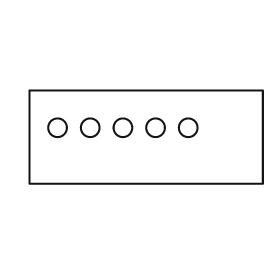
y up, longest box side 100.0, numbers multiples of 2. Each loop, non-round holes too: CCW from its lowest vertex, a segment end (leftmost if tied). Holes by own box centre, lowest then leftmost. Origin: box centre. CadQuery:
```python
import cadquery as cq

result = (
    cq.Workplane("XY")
    .moveTo(-50.0, -20.0)
    .lineTo(50.0, -20.0)
    .lineTo(50.0, 20.0)
    .lineTo(-50.0, 20.0)
    .close()
    .moveTo(-38.0, 4.0)
    .circle(4.0)
    .moveTo(-24.0, 4.0)
    .circle(4.0)
    .moveTo(-10.0, 4.0)
    .circle(4.0)
    .moveTo(4.0, 4.0)
    .circle(4.0)
    .moveTo(18.0, 4.0)
    .circle(4.0)
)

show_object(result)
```